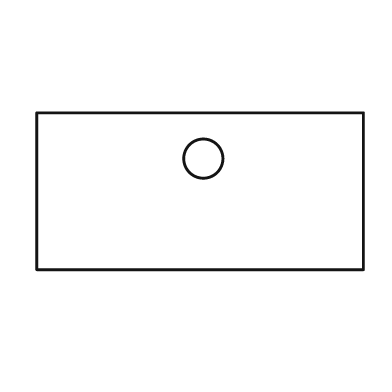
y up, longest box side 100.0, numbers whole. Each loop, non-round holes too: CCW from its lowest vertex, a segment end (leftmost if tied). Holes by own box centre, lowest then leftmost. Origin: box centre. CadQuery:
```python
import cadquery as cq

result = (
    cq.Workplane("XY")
    .moveTo(-50.0, -24.0)
    .lineTo(50.0, -24.0)
    .lineTo(50.0, 24.0)
    .lineTo(-50.0, 24.0)
    .close()
    .moveTo(1.0, 10.0)
    .circle(6.0)
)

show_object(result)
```